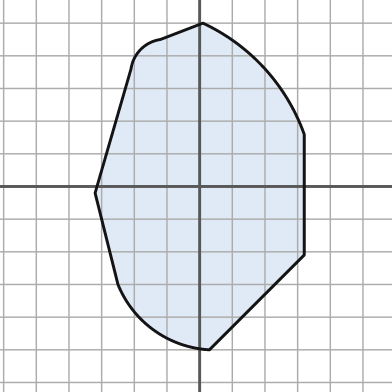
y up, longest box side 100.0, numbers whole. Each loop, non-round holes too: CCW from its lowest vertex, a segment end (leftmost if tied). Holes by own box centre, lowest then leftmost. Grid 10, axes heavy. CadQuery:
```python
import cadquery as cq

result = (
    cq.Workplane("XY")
    .moveTo(3.0, -50.0)
    .lineTo(32.0, -21.0)
    .lineTo(32.0, 16.0)
    .threePointArc((20.0, 36.0), (1.0, 50.0))
    .lineTo(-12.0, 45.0)
    .threePointArc((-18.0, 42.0), (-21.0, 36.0))
    .lineTo(-32.0, -2.0)
    .lineTo(-25.0, -30.0)
    .threePointArc((-14.0, -44.0), (3.0, -50.0))
    .close()
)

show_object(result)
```